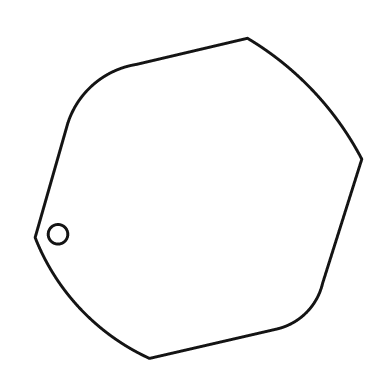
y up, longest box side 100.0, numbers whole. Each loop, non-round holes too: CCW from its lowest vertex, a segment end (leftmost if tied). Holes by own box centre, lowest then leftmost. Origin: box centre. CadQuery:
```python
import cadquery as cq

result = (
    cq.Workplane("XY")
    .moveTo(-15.0, -49.0)
    .lineTo(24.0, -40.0)
    .threePointArc((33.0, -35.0), (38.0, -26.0))
    .lineTo(50.0, 12.0)
    .threePointArc((35.0, 33.0), (15.0, 49.0))
    .lineTo(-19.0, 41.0)
    .threePointArc((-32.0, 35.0), (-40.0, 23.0))
    .lineTo(-50.0, -12.0)
    .threePointArc((-36.0, -34.0), (-15.0, -49.0))
    .close()
    .moveTo(-43.0, -11.0)
    .circle(3.0)
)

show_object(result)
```